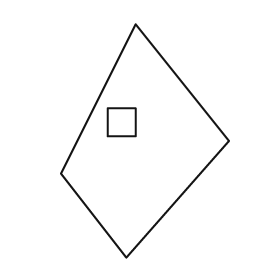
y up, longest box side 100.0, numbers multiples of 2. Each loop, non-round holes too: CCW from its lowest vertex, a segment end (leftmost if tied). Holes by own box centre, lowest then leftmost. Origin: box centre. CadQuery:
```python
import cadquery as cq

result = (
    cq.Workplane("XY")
    .moveTo(-8.0, -50.0)
    .lineTo(36.0, 0.0)
    .lineTo(-4.0, 50.0)
    .lineTo(-36.0, -14.0)
    .close()
    .moveTo(-16.0, 2.0)
    .lineTo(-4.0, 2.0)
    .lineTo(-4.0, 14.0)
    .lineTo(-16.0, 14.0)
    .close()
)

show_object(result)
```